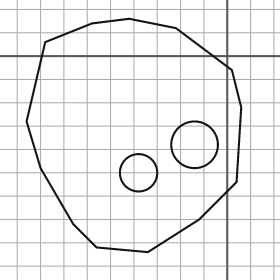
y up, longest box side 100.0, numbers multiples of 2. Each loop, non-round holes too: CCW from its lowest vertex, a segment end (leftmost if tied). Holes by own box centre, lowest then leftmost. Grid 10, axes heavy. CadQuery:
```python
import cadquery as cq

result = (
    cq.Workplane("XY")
    .moveTo(-34.0, -84.0)
    .lineTo(-12.0, -70.0)
    .lineTo(4.0, -54.0)
    .lineTo(6.0, -22.0)
    .lineTo(2.0, -6.0)
    .lineTo(-22.0, 12.0)
    .lineTo(-42.0, 16.0)
    .lineTo(-58.0, 14.0)
    .lineTo(-78.0, 6.0)
    .lineTo(-86.0, -28.0)
    .lineTo(-80.0, -48.0)
    .lineTo(-66.0, -72.0)
    .lineTo(-56.0, -82.0)
    .close()
    .moveTo(-38.0, -50.0)
    .circle(8.0)
    .moveTo(-14.0, -38.0)
    .circle(10.0)
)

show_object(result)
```